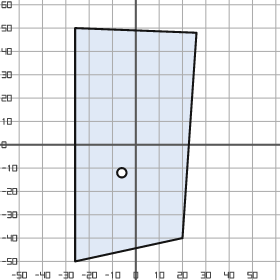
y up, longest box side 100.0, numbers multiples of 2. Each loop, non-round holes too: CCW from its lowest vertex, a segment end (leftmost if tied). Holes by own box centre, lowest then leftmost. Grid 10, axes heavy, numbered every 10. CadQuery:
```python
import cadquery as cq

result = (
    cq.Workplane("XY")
    .moveTo(-26.0, -50.0)
    .lineTo(20.0, -40.0)
    .lineTo(26.0, 48.0)
    .lineTo(-26.0, 50.0)
    .close()
    .moveTo(-6.0, -12.0)
    .circle(2.0)
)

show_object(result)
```